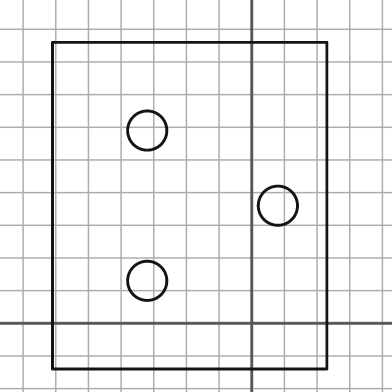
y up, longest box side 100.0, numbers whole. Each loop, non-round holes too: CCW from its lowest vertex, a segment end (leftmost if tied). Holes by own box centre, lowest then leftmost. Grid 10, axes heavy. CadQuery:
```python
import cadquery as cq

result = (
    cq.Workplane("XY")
    .moveTo(-61.0, -14.0)
    .lineTo(23.0, -14.0)
    .lineTo(23.0, 86.0)
    .lineTo(-61.0, 86.0)
    .close()
    .moveTo(-32.0, 13.0)
    .circle(6.0)
    .moveTo(8.0, 36.0)
    .circle(6.0)
    .moveTo(-32.0, 59.0)
    .circle(6.0)
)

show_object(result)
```